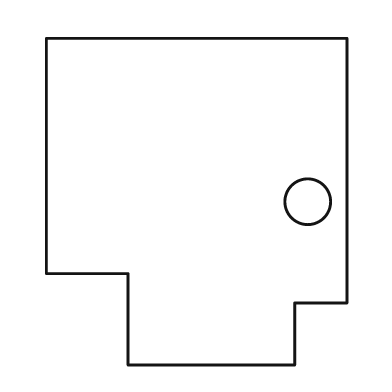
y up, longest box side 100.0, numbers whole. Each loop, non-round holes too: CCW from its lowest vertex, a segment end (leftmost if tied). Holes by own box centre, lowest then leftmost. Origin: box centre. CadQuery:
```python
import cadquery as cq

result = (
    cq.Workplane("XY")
    .moveTo(-21.0, -50.0)
    .lineTo(30.0, -50.0)
    .lineTo(30.0, -31.0)
    .lineTo(46.0, -31.0)
    .lineTo(46.0, 50.0)
    .lineTo(-46.0, 50.0)
    .lineTo(-46.0, -22.0)
    .lineTo(-21.0, -22.0)
    .close()
    .moveTo(34.0, 0.0)
    .circle(7.0)
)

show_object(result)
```